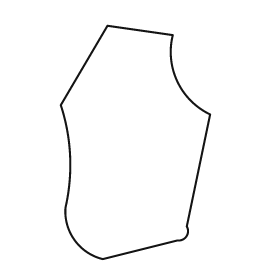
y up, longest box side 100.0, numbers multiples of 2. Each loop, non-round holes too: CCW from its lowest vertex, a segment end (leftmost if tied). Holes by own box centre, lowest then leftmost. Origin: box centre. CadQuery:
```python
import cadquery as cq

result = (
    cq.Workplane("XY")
    .moveTo(-14.0, -50.0)
    .lineTo(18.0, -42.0)
    .threePointArc((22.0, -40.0), (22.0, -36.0))
    .lineTo(32.0, 12.0)
    .threePointArc((18.0, 26.0), (16.0, 46.0))
    .lineTo(-12.0, 50.0)
    .lineTo(-32.0, 16.0)
    .threePointArc((-28.0, -6.0), (-30.0, -28.0))
    .threePointArc((-26.0, -42.0), (-14.0, -50.0))
    .close()
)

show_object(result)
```